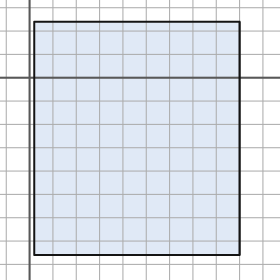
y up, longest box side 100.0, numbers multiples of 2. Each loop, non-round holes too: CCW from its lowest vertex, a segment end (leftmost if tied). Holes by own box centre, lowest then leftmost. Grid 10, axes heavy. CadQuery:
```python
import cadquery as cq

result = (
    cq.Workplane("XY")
    .moveTo(2.0, -76.0)
    .lineTo(90.0, -76.0)
    .lineTo(90.0, 24.0)
    .lineTo(2.0, 24.0)
    .close()
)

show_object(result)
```